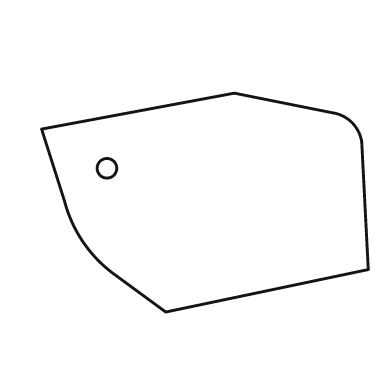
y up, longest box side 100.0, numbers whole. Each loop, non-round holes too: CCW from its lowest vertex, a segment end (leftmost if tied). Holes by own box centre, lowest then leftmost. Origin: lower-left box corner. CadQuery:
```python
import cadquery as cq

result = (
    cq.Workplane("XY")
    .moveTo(38.0, 0.0)
    .lineTo(100.0, 13.0)
    .lineTo(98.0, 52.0)
    .threePointArc((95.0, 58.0), (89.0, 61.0))
    .lineTo(59.0, 67.0)
    .lineTo(0.0, 56.0)
    .lineTo(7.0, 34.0)
    .threePointArc((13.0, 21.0), (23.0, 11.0))
    .close()
    .moveTo(20.0, 44.0)
    .circle(3.0)
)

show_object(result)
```